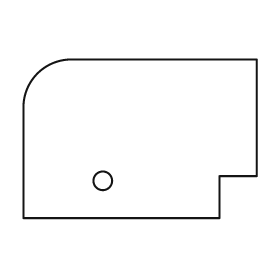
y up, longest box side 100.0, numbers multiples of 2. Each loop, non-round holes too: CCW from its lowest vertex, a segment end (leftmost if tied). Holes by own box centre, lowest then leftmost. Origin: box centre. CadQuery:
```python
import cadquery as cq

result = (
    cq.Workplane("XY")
    .moveTo(-50.0, -34.0)
    .lineTo(34.0, -34.0)
    .lineTo(34.0, -16.0)
    .lineTo(50.0, -16.0)
    .lineTo(50.0, 34.0)
    .lineTo(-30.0, 34.0)
    .threePointArc((-44.0, 28.0), (-50.0, 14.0))
    .close()
    .moveTo(-16.0, -18.0)
    .circle(4.0)
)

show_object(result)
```